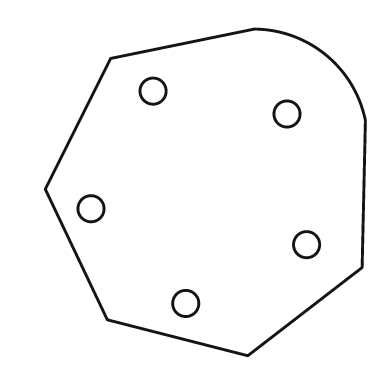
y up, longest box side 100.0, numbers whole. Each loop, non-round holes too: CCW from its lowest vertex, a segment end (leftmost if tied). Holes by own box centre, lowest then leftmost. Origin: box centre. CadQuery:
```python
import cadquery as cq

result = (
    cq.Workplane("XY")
    .moveTo(13.0, -50.0)
    .lineTo(48.0, -23.0)
    .lineTo(49.0, 22.0)
    .threePointArc((37.0, 42.0), (15.0, 50.0))
    .lineTo(-29.0, 41.0)
    .lineTo(-49.0, 1.0)
    .lineTo(-30.0, -39.0)
    .close()
    .moveTo(-6.0, -34.0)
    .circle(4.0)
    .moveTo(31.0, -16.0)
    .circle(4.0)
    .moveTo(-35.0, -5.0)
    .circle(4.0)
    .moveTo(25.0, 24.0)
    .circle(4.0)
    .moveTo(-16.0, 31.0)
    .circle(4.0)
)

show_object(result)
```